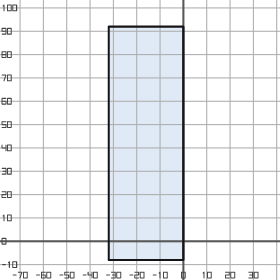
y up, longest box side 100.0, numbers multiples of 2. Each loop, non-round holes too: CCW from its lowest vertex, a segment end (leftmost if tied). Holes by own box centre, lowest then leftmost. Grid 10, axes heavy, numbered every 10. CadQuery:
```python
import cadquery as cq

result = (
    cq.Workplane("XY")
    .moveTo(-32.0, -8.0)
    .lineTo(0.0, -8.0)
    .lineTo(0.0, 92.0)
    .lineTo(-32.0, 92.0)
    .close()
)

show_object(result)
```